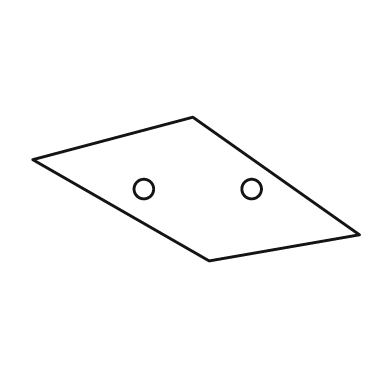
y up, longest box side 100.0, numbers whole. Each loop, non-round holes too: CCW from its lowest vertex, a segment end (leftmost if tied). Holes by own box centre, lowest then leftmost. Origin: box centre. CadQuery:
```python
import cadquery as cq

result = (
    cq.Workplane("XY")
    .moveTo(4.0, -22.0)
    .lineTo(50.0, -14.0)
    .lineTo(-1.0, 22.0)
    .lineTo(-50.0, 9.0)
    .close()
    .moveTo(-16.0, 0.0)
    .circle(3.0)
    .moveTo(17.0, 0.0)
    .circle(3.0)
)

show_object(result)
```